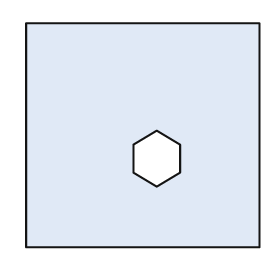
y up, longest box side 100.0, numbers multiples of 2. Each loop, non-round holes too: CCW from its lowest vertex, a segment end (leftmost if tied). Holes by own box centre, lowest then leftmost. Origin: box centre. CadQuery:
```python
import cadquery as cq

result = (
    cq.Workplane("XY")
    .moveTo(-50.0, -48.0)
    .lineTo(50.0, -48.0)
    .lineTo(50.0, 48.0)
    .lineTo(-50.0, 48.0)
    .close()
    .moveTo(6.0, -22.0)
    .lineTo(16.0, -16.0)
    .lineTo(16.0, -4.0)
    .lineTo(6.0, 2.0)
    .lineTo(-4.0, -4.0)
    .lineTo(-4.0, -16.0)
    .close()
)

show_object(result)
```